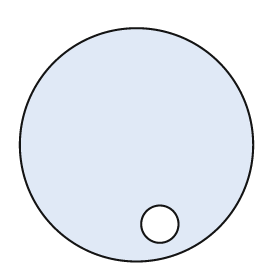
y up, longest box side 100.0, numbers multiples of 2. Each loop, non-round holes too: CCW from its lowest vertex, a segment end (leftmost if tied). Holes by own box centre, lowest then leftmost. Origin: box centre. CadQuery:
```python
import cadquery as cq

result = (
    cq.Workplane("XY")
    .moveTo(0.0, 0.0)
    .circle(50.0)
    .moveTo(10.0, -34.0)
    .circle(8.0)
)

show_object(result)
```